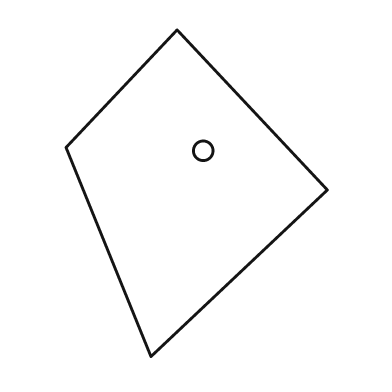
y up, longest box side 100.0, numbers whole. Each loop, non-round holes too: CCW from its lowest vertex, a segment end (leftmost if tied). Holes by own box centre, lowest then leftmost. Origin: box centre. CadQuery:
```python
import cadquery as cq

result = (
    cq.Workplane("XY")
    .moveTo(-14.0, -50.0)
    .lineTo(40.0, 1.0)
    .lineTo(-6.0, 50.0)
    .lineTo(-40.0, 14.0)
    .close()
    .moveTo(2.0, 13.0)
    .circle(3.0)
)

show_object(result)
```